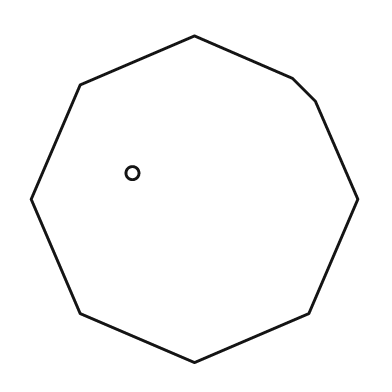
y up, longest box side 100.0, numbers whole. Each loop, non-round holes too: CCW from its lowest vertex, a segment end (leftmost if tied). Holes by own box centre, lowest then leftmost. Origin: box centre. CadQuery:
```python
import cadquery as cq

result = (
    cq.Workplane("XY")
    .moveTo(0.0, -50.0)
    .lineTo(35.0, -35.0)
    .lineTo(50.0, 0.0)
    .lineTo(37.0, 30.0)
    .lineTo(30.0, 37.0)
    .lineTo(0.0, 50.0)
    .lineTo(-35.0, 35.0)
    .lineTo(-50.0, 0.0)
    .lineTo(-35.0, -35.0)
    .close()
    .moveTo(-19.0, 8.0)
    .circle(2.0)
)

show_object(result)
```